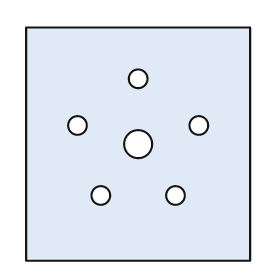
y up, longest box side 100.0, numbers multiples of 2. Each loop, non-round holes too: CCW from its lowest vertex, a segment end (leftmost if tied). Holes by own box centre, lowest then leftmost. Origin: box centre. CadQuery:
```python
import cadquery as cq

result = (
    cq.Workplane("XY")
    .moveTo(-48.0, -50.0)
    .lineTo(48.0, -50.0)
    .lineTo(48.0, 50.0)
    .lineTo(-48.0, 50.0)
    .close()
    .moveTo(-16.0, -22.0)
    .circle(4.0)
    .moveTo(16.0, -22.0)
    .circle(4.0)
    .moveTo(0.0, 0.0)
    .circle(6.0)
    .moveTo(-26.0, 8.0)
    .circle(4.0)
    .moveTo(26.0, 8.0)
    .circle(4.0)
    .moveTo(0.0, 28.0)
    .circle(4.0)
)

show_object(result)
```